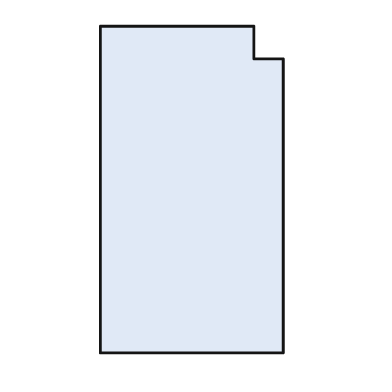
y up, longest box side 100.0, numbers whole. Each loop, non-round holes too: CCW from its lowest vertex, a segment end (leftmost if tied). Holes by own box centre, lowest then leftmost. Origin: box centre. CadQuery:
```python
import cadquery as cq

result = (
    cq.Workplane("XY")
    .moveTo(-28.0, -50.0)
    .lineTo(28.0, -50.0)
    .lineTo(28.0, 40.0)
    .lineTo(19.0, 40.0)
    .lineTo(19.0, 50.0)
    .lineTo(-28.0, 50.0)
    .close()
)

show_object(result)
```